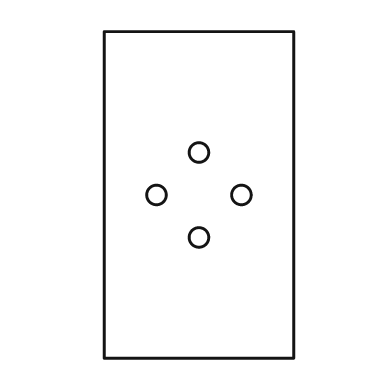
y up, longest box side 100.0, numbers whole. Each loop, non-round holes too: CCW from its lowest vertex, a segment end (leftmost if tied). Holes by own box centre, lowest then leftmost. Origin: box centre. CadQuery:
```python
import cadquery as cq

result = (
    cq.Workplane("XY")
    .moveTo(-29.0, -50.0)
    .lineTo(29.0, -50.0)
    .lineTo(29.0, 50.0)
    .lineTo(-29.0, 50.0)
    .close()
    .moveTo(0.0, -13.0)
    .circle(3.0)
    .moveTo(-13.0, 0.0)
    .circle(3.0)
    .moveTo(13.0, 0.0)
    .circle(3.0)
    .moveTo(0.0, 13.0)
    .circle(3.0)
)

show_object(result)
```